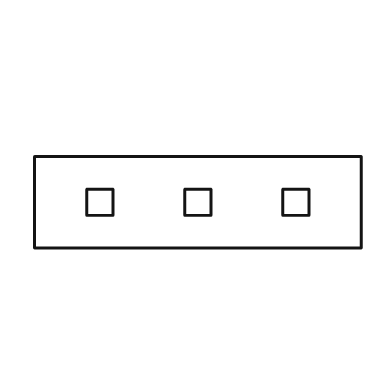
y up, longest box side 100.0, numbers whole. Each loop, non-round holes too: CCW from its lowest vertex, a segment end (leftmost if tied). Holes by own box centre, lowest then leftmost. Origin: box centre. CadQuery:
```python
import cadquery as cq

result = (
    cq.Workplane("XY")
    .moveTo(-50.0, -14.0)
    .lineTo(50.0, -14.0)
    .lineTo(50.0, 14.0)
    .lineTo(-50.0, 14.0)
    .close()
    .moveTo(-34.0, -4.0)
    .lineTo(-26.0, -4.0)
    .lineTo(-26.0, 4.0)
    .lineTo(-34.0, 4.0)
    .close()
    .moveTo(-4.0, -4.0)
    .lineTo(4.0, -4.0)
    .lineTo(4.0, 4.0)
    .lineTo(-4.0, 4.0)
    .close()
    .moveTo(26.0, -4.0)
    .lineTo(34.0, -4.0)
    .lineTo(34.0, 4.0)
    .lineTo(26.0, 4.0)
    .close()
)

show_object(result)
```